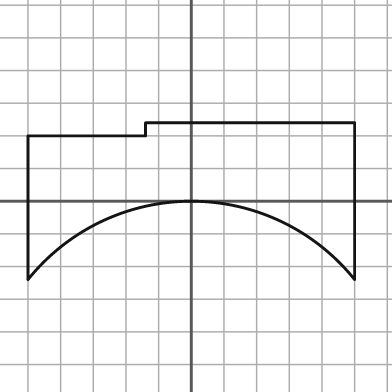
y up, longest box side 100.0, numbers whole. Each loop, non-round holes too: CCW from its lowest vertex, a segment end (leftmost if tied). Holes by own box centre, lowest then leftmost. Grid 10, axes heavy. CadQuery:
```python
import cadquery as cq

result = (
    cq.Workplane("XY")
    .moveTo(-50.0, -24.0)
    .threePointArc((0.0, 0.0), (50.0, -24.0))
    .lineTo(50.0, 24.0)
    .lineTo(-14.0, 24.0)
    .lineTo(-14.0, 20.0)
    .lineTo(-50.0, 20.0)
    .close()
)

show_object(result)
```